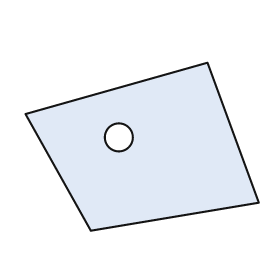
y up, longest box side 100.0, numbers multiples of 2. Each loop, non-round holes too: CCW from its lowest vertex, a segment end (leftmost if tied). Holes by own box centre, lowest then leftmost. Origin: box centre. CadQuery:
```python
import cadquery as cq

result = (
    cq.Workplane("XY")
    .moveTo(-22.0, -36.0)
    .lineTo(50.0, -24.0)
    .lineTo(28.0, 36.0)
    .lineTo(-50.0, 14.0)
    .close()
    .moveTo(-10.0, 4.0)
    .circle(6.0)
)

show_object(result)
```